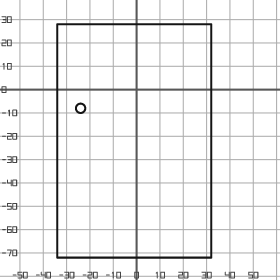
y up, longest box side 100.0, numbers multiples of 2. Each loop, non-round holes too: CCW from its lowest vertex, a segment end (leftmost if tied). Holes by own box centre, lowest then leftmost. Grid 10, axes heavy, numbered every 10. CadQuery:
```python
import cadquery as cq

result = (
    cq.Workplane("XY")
    .moveTo(-34.0, -72.0)
    .lineTo(32.0, -72.0)
    .lineTo(32.0, 28.0)
    .lineTo(-34.0, 28.0)
    .close()
    .moveTo(-24.0, -8.0)
    .circle(2.0)
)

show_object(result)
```